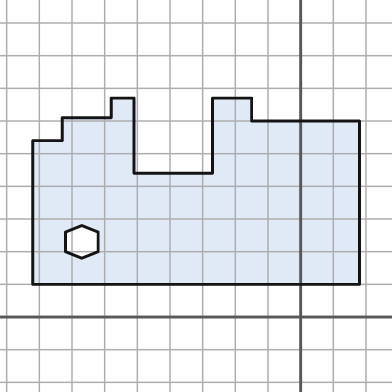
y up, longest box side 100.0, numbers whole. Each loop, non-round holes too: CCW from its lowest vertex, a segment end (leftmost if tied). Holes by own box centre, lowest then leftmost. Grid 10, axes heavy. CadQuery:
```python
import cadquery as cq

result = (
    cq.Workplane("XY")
    .moveTo(-82.0, 10.0)
    .lineTo(18.0, 10.0)
    .lineTo(18.0, 60.0)
    .lineTo(-15.0, 60.0)
    .lineTo(-15.0, 67.0)
    .lineTo(-27.0, 67.0)
    .lineTo(-27.0, 44.0)
    .lineTo(-51.0, 44.0)
    .lineTo(-51.0, 67.0)
    .lineTo(-58.0, 67.0)
    .lineTo(-58.0, 61.0)
    .lineTo(-73.0, 61.0)
    .lineTo(-73.0, 54.0)
    .lineTo(-82.0, 54.0)
    .close()
    .moveTo(-67.0, 18.0)
    .lineTo(-62.0, 20.0)
    .lineTo(-62.0, 26.0)
    .lineTo(-67.0, 28.0)
    .lineTo(-72.0, 26.0)
    .lineTo(-72.0, 20.0)
    .close()
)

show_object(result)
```